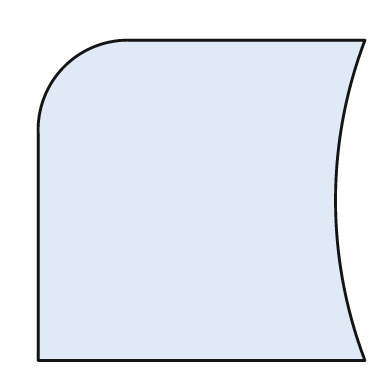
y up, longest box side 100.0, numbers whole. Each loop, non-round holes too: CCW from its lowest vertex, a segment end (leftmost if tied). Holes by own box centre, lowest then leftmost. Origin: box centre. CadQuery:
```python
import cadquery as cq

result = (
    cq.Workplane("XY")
    .moveTo(-50.0, -49.0)
    .lineTo(50.0, -49.0)
    .threePointArc((41.0, 0.0), (50.0, 49.0))
    .lineTo(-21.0, 49.0)
    .threePointArc((-42.0, 41.0), (-50.0, 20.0))
    .close()
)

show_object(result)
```